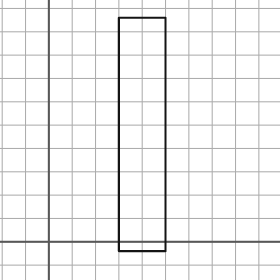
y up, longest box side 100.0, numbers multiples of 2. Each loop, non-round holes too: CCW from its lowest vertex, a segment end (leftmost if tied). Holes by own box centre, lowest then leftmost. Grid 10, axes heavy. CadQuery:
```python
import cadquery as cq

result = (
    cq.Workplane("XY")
    .moveTo(30.0, -4.0)
    .lineTo(50.0, -4.0)
    .lineTo(50.0, 96.0)
    .lineTo(30.0, 96.0)
    .close()
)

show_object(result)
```